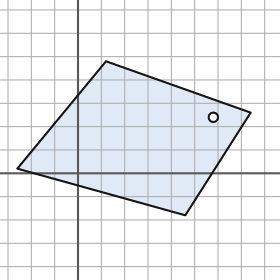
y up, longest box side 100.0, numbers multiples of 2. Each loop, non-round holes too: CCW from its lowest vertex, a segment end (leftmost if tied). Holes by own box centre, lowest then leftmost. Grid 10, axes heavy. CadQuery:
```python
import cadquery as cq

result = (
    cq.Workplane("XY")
    .moveTo(46.0, -18.0)
    .lineTo(74.0, 26.0)
    .lineTo(12.0, 48.0)
    .lineTo(-26.0, 2.0)
    .close()
    .moveTo(58.0, 24.0)
    .circle(2.0)
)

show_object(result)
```